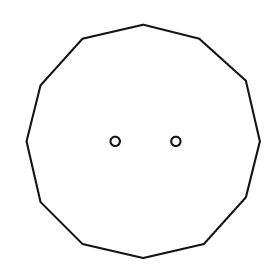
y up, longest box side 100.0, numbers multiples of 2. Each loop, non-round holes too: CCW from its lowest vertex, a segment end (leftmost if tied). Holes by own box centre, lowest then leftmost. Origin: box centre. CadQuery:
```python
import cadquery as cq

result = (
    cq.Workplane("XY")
    .moveTo(0.0, -50.0)
    .lineTo(26.0, -44.0)
    .lineTo(44.0, -24.0)
    .lineTo(50.0, 0.0)
    .lineTo(44.0, 26.0)
    .lineTo(24.0, 44.0)
    .lineTo(0.0, 50.0)
    .lineTo(-26.0, 44.0)
    .lineTo(-44.0, 24.0)
    .lineTo(-50.0, 0.0)
    .lineTo(-44.0, -26.0)
    .lineTo(-26.0, -44.0)
    .close()
    .moveTo(-12.0, 0.0)
    .circle(2.0)
    .moveTo(14.0, 0.0)
    .circle(2.0)
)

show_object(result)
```